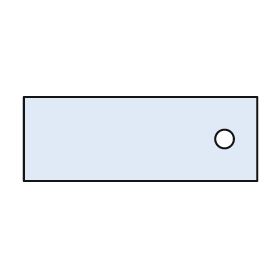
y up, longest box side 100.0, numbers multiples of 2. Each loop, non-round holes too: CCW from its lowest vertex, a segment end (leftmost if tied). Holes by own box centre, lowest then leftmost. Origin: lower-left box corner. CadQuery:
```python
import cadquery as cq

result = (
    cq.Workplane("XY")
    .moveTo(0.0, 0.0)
    .lineTo(100.0, 0.0)
    .lineTo(100.0, 36.0)
    .lineTo(0.0, 36.0)
    .close()
    .moveTo(86.0, 18.0)
    .circle(4.0)
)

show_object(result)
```